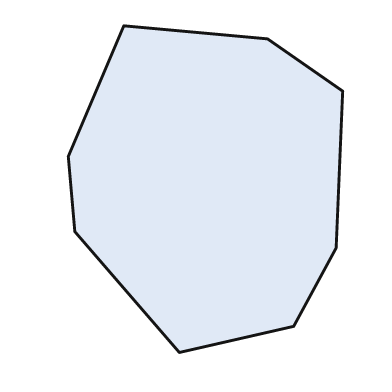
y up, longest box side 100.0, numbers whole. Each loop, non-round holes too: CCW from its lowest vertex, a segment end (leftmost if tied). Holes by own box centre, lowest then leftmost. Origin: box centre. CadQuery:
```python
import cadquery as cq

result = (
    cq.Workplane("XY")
    .moveTo(-8.0, -50.0)
    .lineTo(27.0, -42.0)
    .lineTo(40.0, -18.0)
    .lineTo(42.0, 30.0)
    .lineTo(19.0, 46.0)
    .lineTo(-25.0, 50.0)
    .lineTo(-42.0, 10.0)
    .lineTo(-40.0, -13.0)
    .close()
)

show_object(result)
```